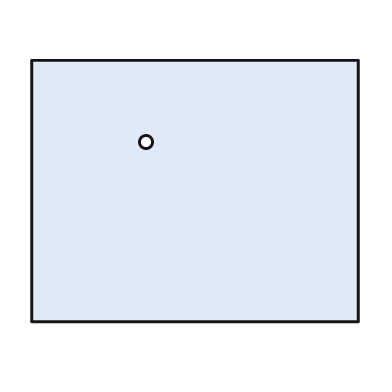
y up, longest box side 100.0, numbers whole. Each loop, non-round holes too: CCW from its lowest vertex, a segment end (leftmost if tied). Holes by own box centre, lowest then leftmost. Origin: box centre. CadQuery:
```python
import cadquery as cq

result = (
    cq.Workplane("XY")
    .moveTo(-50.0, -40.0)
    .lineTo(50.0, -40.0)
    .lineTo(50.0, 40.0)
    .lineTo(-50.0, 40.0)
    .close()
    .moveTo(-15.0, 15.0)
    .circle(2.0)
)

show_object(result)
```